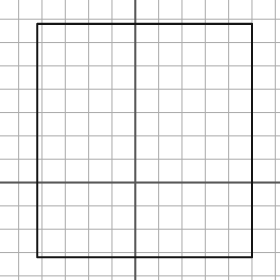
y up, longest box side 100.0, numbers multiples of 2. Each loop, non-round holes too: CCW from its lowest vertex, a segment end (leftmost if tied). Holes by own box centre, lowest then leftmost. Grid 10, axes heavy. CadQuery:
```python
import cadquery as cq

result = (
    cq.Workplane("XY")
    .moveTo(-42.0, -32.0)
    .lineTo(50.0, -32.0)
    .lineTo(50.0, 68.0)
    .lineTo(-42.0, 68.0)
    .close()
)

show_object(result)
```